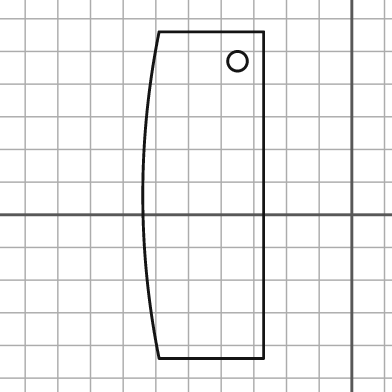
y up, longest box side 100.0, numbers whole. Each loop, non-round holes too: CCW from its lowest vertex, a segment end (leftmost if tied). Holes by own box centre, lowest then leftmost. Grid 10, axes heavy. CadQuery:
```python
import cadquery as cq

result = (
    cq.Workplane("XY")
    .moveTo(-59.0, -44.0)
    .lineTo(-27.0, -44.0)
    .lineTo(-27.0, 56.0)
    .lineTo(-59.0, 56.0)
    .threePointArc((-64.0, 6.0), (-59.0, -44.0))
    .close()
    .moveTo(-35.0, 47.0)
    .circle(3.0)
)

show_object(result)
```